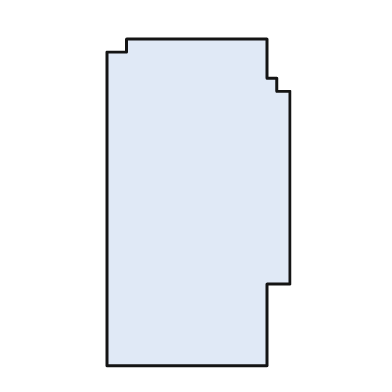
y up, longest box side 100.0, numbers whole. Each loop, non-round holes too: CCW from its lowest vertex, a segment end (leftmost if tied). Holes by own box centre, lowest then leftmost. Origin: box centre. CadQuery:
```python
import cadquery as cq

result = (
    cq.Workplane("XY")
    .moveTo(-28.0, -50.0)
    .lineTo(21.0, -50.0)
    .lineTo(21.0, -25.0)
    .lineTo(28.0, -25.0)
    .lineTo(28.0, 34.0)
    .lineTo(24.0, 34.0)
    .lineTo(24.0, 38.0)
    .lineTo(21.0, 38.0)
    .lineTo(21.0, 50.0)
    .lineTo(-22.0, 50.0)
    .lineTo(-22.0, 46.0)
    .lineTo(-28.0, 46.0)
    .close()
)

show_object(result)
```